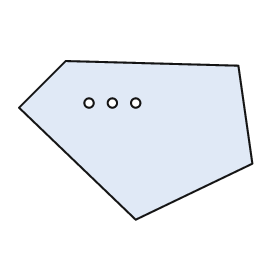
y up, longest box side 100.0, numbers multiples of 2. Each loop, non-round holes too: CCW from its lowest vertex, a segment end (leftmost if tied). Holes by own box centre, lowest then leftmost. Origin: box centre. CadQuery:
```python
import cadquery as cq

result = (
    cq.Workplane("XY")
    .moveTo(0.0, -34.0)
    .lineTo(50.0, -10.0)
    .lineTo(44.0, 32.0)
    .lineTo(-30.0, 34.0)
    .lineTo(-50.0, 14.0)
    .close()
    .moveTo(-20.0, 16.0)
    .circle(2.0)
    .moveTo(-10.0, 16.0)
    .circle(2.0)
    .moveTo(0.0, 16.0)
    .circle(2.0)
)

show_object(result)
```